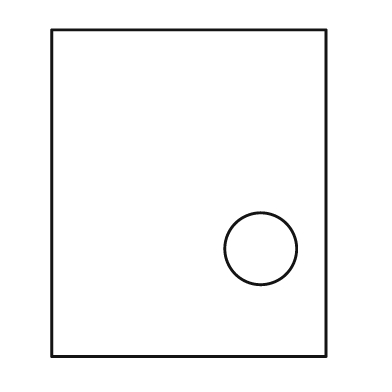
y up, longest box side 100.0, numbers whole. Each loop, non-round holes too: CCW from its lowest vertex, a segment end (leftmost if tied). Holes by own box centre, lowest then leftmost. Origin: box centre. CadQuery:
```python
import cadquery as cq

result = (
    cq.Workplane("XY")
    .moveTo(-42.0, -50.0)
    .lineTo(42.0, -50.0)
    .lineTo(42.0, 50.0)
    .lineTo(-42.0, 50.0)
    .close()
    .moveTo(22.0, -17.0)
    .circle(11.0)
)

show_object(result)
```